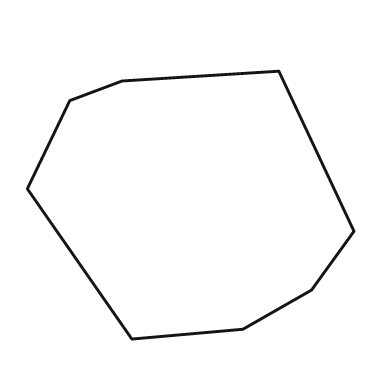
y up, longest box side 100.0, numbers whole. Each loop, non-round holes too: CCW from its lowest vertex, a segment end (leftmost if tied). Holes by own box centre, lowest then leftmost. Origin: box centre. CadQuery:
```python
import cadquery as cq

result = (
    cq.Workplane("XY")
    .moveTo(-18.0, -41.0)
    .lineTo(16.0, -38.0)
    .lineTo(37.0, -26.0)
    .lineTo(50.0, -8.0)
    .lineTo(27.0, 41.0)
    .lineTo(-21.0, 38.0)
    .lineTo(-37.0, 32.0)
    .lineTo(-50.0, 5.0)
    .close()
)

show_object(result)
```